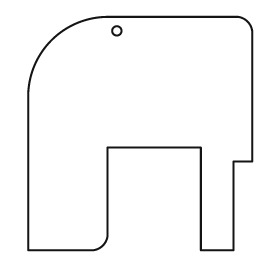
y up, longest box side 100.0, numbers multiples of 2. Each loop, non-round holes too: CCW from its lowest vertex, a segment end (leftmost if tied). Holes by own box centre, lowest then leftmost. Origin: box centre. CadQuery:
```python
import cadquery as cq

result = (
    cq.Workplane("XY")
    .moveTo(-48.0, -50.0)
    .lineTo(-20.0, -50.0)
    .threePointArc((-16.0, -48.0), (-14.0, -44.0))
    .lineTo(-14.0, -6.0)
    .lineTo(26.0, -6.0)
    .lineTo(26.0, -50.0)
    .lineTo(40.0, -50.0)
    .lineTo(40.0, -12.0)
    .lineTo(48.0, -12.0)
    .lineTo(48.0, 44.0)
    .threePointArc((46.0, 48.0), (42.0, 50.0))
    .lineTo(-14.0, 50.0)
    .threePointArc((-38.0, 40.0), (-48.0, 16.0))
    .close()
    .moveTo(-10.0, 44.0)
    .circle(2.0)
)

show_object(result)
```